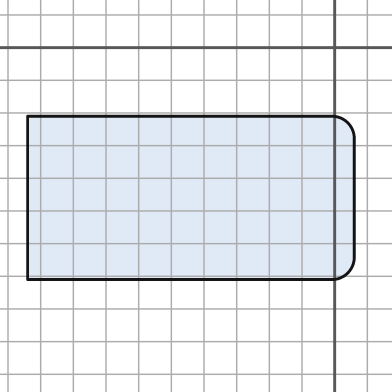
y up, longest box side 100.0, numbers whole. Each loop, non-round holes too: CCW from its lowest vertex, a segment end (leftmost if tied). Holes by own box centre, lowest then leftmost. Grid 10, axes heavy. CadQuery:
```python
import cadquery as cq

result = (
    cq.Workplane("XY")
    .moveTo(-94.0, -71.0)
    .lineTo(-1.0, -71.0)
    .threePointArc((4.0, -69.0), (6.0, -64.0))
    .lineTo(6.0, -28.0)
    .threePointArc((4.0, -23.0), (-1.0, -21.0))
    .lineTo(-94.0, -21.0)
    .close()
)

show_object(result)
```